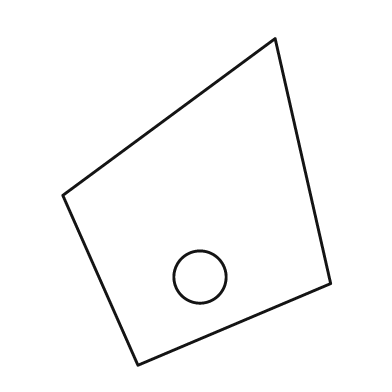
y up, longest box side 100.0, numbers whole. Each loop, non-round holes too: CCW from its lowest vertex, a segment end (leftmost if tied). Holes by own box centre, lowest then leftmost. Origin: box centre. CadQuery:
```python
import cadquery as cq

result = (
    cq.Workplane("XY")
    .moveTo(-18.0, -50.0)
    .lineTo(41.0, -25.0)
    .lineTo(24.0, 50.0)
    .lineTo(-41.0, 2.0)
    .close()
    .moveTo(1.0, -23.0)
    .circle(8.0)
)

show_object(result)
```